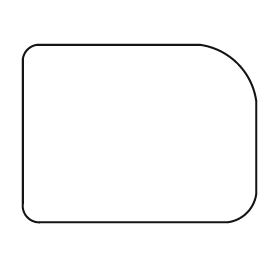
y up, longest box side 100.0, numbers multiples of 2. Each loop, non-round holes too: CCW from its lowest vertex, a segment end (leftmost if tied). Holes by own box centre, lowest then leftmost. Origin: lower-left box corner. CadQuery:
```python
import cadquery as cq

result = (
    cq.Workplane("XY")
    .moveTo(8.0, 0.0)
    .lineTo(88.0, 0.0)
    .threePointArc((96.0, 4.0), (100.0, 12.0))
    .lineTo(100.0, 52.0)
    .threePointArc((92.0, 68.0), (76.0, 76.0))
    .lineTo(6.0, 76.0)
    .threePointArc((2.0, 74.0), (0.0, 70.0))
    .lineTo(0.0, 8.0)
    .threePointArc((2.0, 2.0), (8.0, 0.0))
    .close()
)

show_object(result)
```